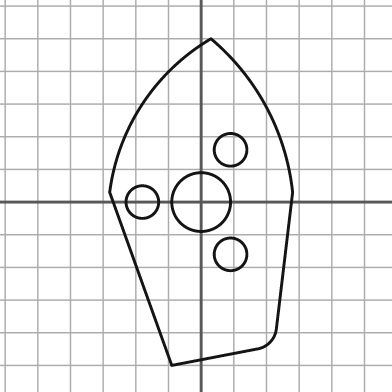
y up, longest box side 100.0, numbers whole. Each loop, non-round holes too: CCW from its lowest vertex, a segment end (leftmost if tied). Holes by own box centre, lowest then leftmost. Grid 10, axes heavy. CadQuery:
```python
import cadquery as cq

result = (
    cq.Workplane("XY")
    .moveTo(-9.0, -50.0)
    .lineTo(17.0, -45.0)
    .threePointArc((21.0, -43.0), (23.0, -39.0))
    .lineTo(28.0, 3.0)
    .threePointArc((20.0, 29.0), (3.0, 50.0))
    .threePointArc((-18.0, 30.0), (-28.0, 3.0))
    .close()
    .moveTo(9.0, -16.0)
    .circle(5.0)
    .moveTo(-18.0, 0.0)
    .circle(5.0)
    .moveTo(0.0, 0.0)
    .circle(9.0)
    .moveTo(9.0, 16.0)
    .circle(5.0)
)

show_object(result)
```